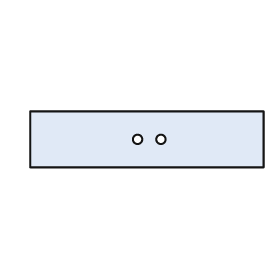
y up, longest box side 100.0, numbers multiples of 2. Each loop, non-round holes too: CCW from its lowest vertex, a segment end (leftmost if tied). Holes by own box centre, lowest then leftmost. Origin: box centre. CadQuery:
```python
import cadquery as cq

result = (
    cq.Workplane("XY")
    .moveTo(-50.0, -12.0)
    .lineTo(50.0, -12.0)
    .lineTo(50.0, 12.0)
    .lineTo(-50.0, 12.0)
    .close()
    .moveTo(-4.0, 0.0)
    .circle(2.0)
    .moveTo(6.0, 0.0)
    .circle(2.0)
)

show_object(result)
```